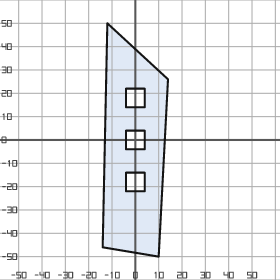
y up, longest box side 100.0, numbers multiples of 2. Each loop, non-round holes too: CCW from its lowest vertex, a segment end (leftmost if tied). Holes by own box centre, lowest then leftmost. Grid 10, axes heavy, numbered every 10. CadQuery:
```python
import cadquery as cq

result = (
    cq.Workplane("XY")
    .moveTo(10.0, -50.0)
    .lineTo(14.0, 26.0)
    .lineTo(-12.0, 50.0)
    .lineTo(-14.0, -46.0)
    .close()
    .moveTo(-4.0, -22.0)
    .lineTo(4.0, -22.0)
    .lineTo(4.0, -14.0)
    .lineTo(-4.0, -14.0)
    .close()
    .moveTo(-4.0, -4.0)
    .lineTo(4.0, -4.0)
    .lineTo(4.0, 4.0)
    .lineTo(-4.0, 4.0)
    .close()
    .moveTo(-4.0, 14.0)
    .lineTo(4.0, 14.0)
    .lineTo(4.0, 22.0)
    .lineTo(-4.0, 22.0)
    .close()
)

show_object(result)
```